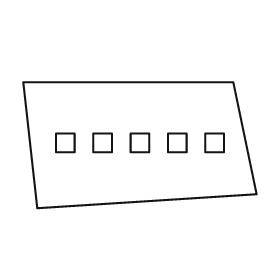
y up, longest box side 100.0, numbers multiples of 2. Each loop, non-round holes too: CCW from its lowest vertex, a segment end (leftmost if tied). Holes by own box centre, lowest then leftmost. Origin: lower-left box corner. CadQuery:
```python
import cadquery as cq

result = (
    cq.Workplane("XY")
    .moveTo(6.0, 0.0)
    .lineTo(100.0, 6.0)
    .lineTo(90.0, 54.0)
    .lineTo(0.0, 54.0)
    .close()
    .moveTo(14.0, 24.0)
    .lineTo(22.0, 24.0)
    .lineTo(22.0, 32.0)
    .lineTo(14.0, 32.0)
    .close()
    .moveTo(30.0, 24.0)
    .lineTo(38.0, 24.0)
    .lineTo(38.0, 32.0)
    .lineTo(30.0, 32.0)
    .close()
    .moveTo(46.0, 24.0)
    .lineTo(54.0, 24.0)
    .lineTo(54.0, 32.0)
    .lineTo(46.0, 32.0)
    .close()
    .moveTo(62.0, 24.0)
    .lineTo(70.0, 24.0)
    .lineTo(70.0, 32.0)
    .lineTo(62.0, 32.0)
    .close()
    .moveTo(78.0, 24.0)
    .lineTo(86.0, 24.0)
    .lineTo(86.0, 32.0)
    .lineTo(78.0, 32.0)
    .close()
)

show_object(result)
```